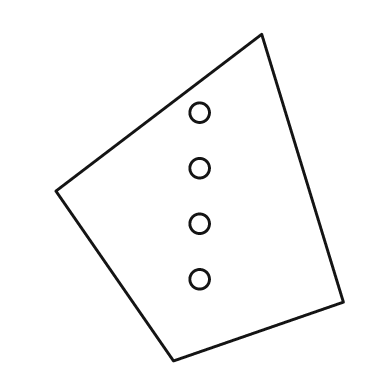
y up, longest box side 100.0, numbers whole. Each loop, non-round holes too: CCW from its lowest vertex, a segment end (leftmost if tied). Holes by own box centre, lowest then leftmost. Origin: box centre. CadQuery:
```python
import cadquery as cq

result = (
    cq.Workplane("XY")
    .moveTo(-8.0, -50.0)
    .lineTo(44.0, -32.0)
    .lineTo(19.0, 50.0)
    .lineTo(-44.0, 2.0)
    .close()
    .moveTo(0.0, -25.0)
    .circle(3.0)
    .moveTo(0.0, -8.0)
    .circle(3.0)
    .moveTo(0.0, 9.0)
    .circle(3.0)
    .moveTo(0.0, 26.0)
    .circle(3.0)
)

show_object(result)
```